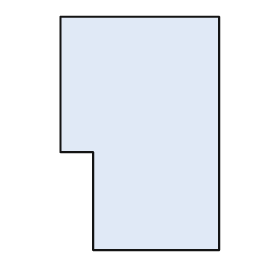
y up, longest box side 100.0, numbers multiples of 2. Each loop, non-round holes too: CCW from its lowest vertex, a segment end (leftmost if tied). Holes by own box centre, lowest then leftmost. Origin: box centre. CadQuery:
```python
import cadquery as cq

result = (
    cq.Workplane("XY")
    .moveTo(-20.0, -50.0)
    .lineTo(34.0, -50.0)
    .lineTo(34.0, 50.0)
    .lineTo(-34.0, 50.0)
    .lineTo(-34.0, -8.0)
    .lineTo(-20.0, -8.0)
    .close()
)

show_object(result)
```